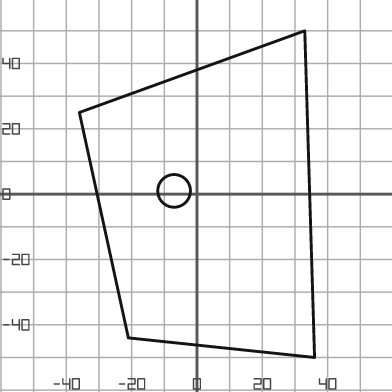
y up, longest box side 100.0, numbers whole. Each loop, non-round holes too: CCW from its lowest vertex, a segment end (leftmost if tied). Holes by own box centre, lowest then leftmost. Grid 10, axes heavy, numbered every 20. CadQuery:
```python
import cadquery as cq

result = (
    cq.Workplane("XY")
    .moveTo(36.0, -50.0)
    .lineTo(33.0, 50.0)
    .lineTo(-36.0, 25.0)
    .lineTo(-21.0, -44.0)
    .close()
    .moveTo(-7.0, 1.0)
    .circle(5.0)
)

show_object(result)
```